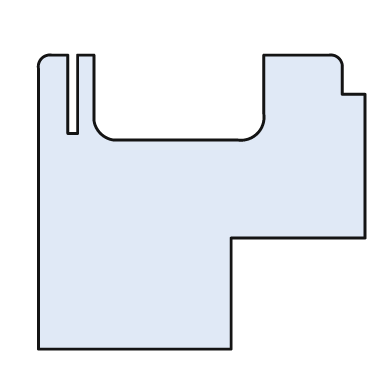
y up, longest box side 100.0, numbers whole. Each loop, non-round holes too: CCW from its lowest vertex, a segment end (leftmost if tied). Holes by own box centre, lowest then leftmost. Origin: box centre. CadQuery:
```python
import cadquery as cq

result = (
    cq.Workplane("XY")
    .moveTo(-50.0, -45.0)
    .lineTo(9.0, -45.0)
    .lineTo(9.0, -11.0)
    .lineTo(50.0, -11.0)
    .lineTo(50.0, 33.0)
    .lineTo(43.0, 33.0)
    .lineTo(43.0, 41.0)
    .threePointArc((42.0, 44.0), (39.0, 45.0))
    .lineTo(19.0, 45.0)
    .lineTo(19.0, 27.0)
    .threePointArc((17.0, 21.0), (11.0, 19.0))
    .lineTo(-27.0, 19.0)
    .threePointArc((-31.0, 21.0), (-33.0, 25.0))
    .lineTo(-33.0, 45.0)
    .lineTo(-38.0, 45.0)
    .lineTo(-38.0, 21.0)
    .lineTo(-41.0, 21.0)
    .lineTo(-41.0, 45.0)
    .lineTo(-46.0, 45.0)
    .threePointArc((-49.0, 44.0), (-50.0, 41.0))
    .close()
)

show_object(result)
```